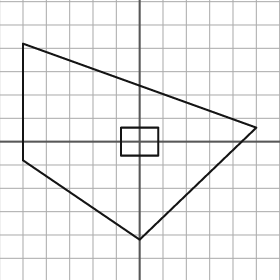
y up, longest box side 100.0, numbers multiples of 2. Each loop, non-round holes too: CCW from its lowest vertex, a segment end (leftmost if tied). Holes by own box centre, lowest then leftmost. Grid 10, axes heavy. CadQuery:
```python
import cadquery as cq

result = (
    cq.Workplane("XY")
    .moveTo(0.0, -42.0)
    .lineTo(50.0, 6.0)
    .lineTo(-50.0, 42.0)
    .lineTo(-50.0, -8.0)
    .close()
    .moveTo(-8.0, -6.0)
    .lineTo(8.0, -6.0)
    .lineTo(8.0, 6.0)
    .lineTo(-8.0, 6.0)
    .close()
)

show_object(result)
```